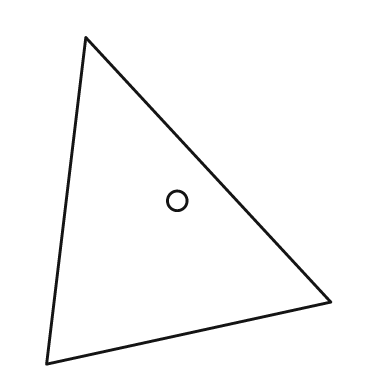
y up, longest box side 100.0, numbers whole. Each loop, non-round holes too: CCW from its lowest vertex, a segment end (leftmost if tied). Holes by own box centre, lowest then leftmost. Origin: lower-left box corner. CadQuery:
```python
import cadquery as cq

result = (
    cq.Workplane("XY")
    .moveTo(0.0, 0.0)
    .lineTo(87.0, 19.0)
    .lineTo(12.0, 100.0)
    .close()
    .moveTo(40.0, 50.0)
    .circle(3.0)
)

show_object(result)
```